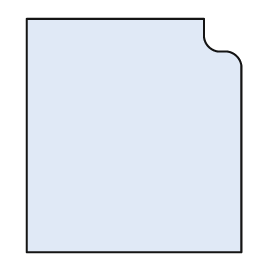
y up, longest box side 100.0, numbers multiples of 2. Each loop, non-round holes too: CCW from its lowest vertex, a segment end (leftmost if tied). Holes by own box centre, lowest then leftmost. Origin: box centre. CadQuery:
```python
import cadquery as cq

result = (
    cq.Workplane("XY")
    .moveTo(-46.0, -50.0)
    .lineTo(46.0, -50.0)
    .lineTo(46.0, 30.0)
    .threePointArc((44.0, 34.0), (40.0, 36.0))
    .lineTo(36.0, 36.0)
    .threePointArc((32.0, 38.0), (30.0, 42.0))
    .lineTo(30.0, 50.0)
    .lineTo(-46.0, 50.0)
    .close()
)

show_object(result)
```